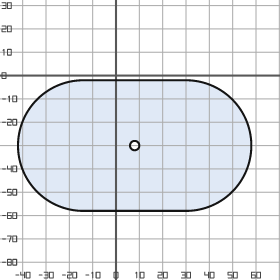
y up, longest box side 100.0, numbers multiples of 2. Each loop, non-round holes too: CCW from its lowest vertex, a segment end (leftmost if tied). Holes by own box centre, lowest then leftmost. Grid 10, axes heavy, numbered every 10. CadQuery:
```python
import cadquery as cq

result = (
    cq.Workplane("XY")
    .moveTo(-14.0, -58.0)
    .lineTo(30.0, -58.0)
    .threePointArc((58.0, -30.0), (30.0, -2.0))
    .lineTo(-14.0, -2.0)
    .threePointArc((-42.0, -30.0), (-14.0, -58.0))
    .close()
    .moveTo(8.0, -30.0)
    .circle(2.0)
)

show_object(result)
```